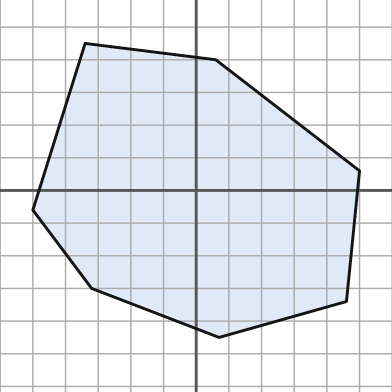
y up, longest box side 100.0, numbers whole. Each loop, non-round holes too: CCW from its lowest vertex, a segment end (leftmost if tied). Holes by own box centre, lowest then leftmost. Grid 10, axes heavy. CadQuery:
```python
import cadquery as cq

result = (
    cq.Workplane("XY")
    .moveTo(7.0, -45.0)
    .lineTo(46.0, -34.0)
    .lineTo(50.0, 6.0)
    .lineTo(6.0, 40.0)
    .lineTo(-34.0, 45.0)
    .lineTo(-50.0, -6.0)
    .lineTo(-32.0, -30.0)
    .close()
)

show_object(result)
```